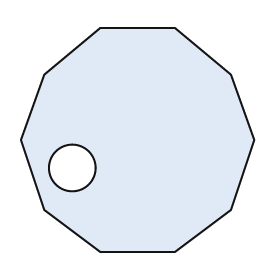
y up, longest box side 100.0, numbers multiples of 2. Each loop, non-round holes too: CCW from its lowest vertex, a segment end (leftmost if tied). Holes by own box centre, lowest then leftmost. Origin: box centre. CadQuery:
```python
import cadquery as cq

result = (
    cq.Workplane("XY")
    .moveTo(-16.0, -48.0)
    .lineTo(16.0, -48.0)
    .lineTo(40.0, -30.0)
    .lineTo(50.0, 0.0)
    .lineTo(40.0, 28.0)
    .lineTo(16.0, 48.0)
    .lineTo(-16.0, 48.0)
    .lineTo(-40.0, 28.0)
    .lineTo(-50.0, 0.0)
    .lineTo(-40.0, -30.0)
    .close()
    .moveTo(-28.0, -12.0)
    .circle(10.0)
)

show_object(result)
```